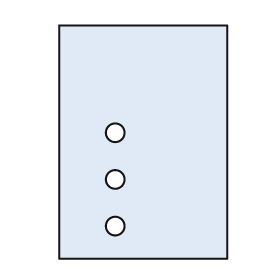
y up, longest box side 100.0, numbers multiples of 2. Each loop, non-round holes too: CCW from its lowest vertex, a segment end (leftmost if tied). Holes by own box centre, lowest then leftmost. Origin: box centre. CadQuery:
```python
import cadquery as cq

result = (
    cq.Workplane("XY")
    .moveTo(-36.0, -50.0)
    .lineTo(36.0, -50.0)
    .lineTo(36.0, 50.0)
    .lineTo(-36.0, 50.0)
    .close()
    .moveTo(-12.0, -36.0)
    .circle(4.0)
    .moveTo(-12.0, -16.0)
    .circle(4.0)
    .moveTo(-12.0, 4.0)
    .circle(4.0)
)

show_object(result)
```